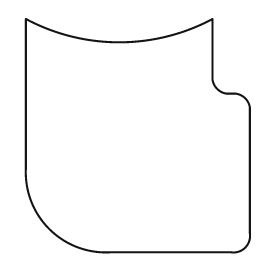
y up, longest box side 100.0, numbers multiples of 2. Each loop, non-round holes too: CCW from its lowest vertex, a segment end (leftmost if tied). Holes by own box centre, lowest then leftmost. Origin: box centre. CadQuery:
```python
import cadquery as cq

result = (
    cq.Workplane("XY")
    .moveTo(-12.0, -50.0)
    .lineTo(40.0, -50.0)
    .threePointArc((46.0, -48.0), (48.0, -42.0))
    .lineTo(48.0, 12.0)
    .threePointArc((46.0, 16.0), (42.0, 18.0))
    .lineTo(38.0, 18.0)
    .threePointArc((34.0, 20.0), (32.0, 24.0))
    .lineTo(32.0, 50.0)
    .threePointArc((-8.0, 40.0), (-48.0, 50.0))
    .lineTo(-48.0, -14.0)
    .threePointArc((-38.0, -40.0), (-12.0, -50.0))
    .close()
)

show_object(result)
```